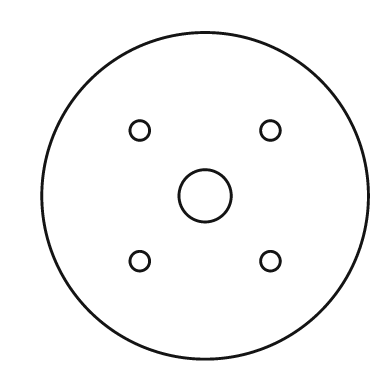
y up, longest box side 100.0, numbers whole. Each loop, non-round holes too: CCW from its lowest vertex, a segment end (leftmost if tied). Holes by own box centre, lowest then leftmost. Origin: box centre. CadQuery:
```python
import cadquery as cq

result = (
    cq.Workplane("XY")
    .moveTo(0.0, 0.0)
    .circle(50.0)
    .moveTo(-20.0, -20.0)
    .circle(3.0)
    .moveTo(20.0, -20.0)
    .circle(3.0)
    .moveTo(0.0, 0.0)
    .circle(8.0)
    .moveTo(-20.0, 20.0)
    .circle(3.0)
    .moveTo(20.0, 20.0)
    .circle(3.0)
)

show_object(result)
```